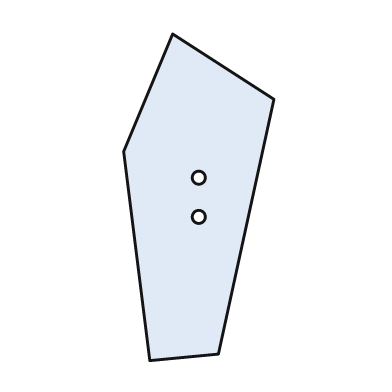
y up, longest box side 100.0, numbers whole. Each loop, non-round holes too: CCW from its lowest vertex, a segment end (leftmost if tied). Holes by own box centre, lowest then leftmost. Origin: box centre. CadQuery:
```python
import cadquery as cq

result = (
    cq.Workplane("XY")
    .moveTo(-15.0, -50.0)
    .lineTo(6.0, -48.0)
    .lineTo(23.0, 30.0)
    .lineTo(-8.0, 50.0)
    .lineTo(-23.0, 14.0)
    .close()
    .moveTo(0.0, -6.0)
    .circle(2.0)
    .moveTo(0.0, 6.0)
    .circle(2.0)
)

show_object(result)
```